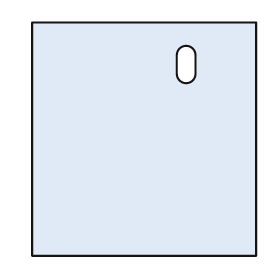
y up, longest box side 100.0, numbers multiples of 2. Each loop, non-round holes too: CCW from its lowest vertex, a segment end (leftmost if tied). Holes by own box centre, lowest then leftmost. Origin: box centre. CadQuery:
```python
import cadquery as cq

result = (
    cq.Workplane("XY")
    .moveTo(-48.0, -50.0)
    .lineTo(48.0, -50.0)
    .lineTo(48.0, 50.0)
    .lineTo(-48.0, 50.0)
    .close()
    .moveTo(14.0, 28.0)
    .threePointArc((18.0, 24.0), (22.0, 28.0))
    .lineTo(22.0, 36.0)
    .threePointArc((18.0, 40.0), (14.0, 36.0))
    .close()
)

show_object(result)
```